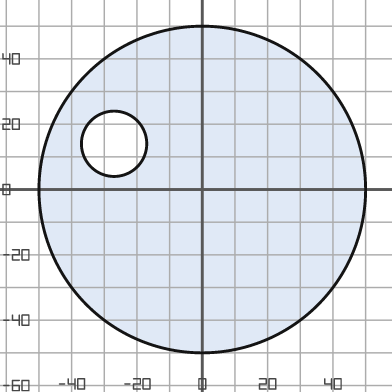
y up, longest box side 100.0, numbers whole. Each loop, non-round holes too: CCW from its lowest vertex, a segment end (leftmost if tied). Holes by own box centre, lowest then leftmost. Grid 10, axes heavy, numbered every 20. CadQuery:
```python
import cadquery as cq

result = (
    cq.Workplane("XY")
    .moveTo(0.0, 0.0)
    .circle(50.0)
    .moveTo(-27.0, 14.0)
    .circle(10.0)
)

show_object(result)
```